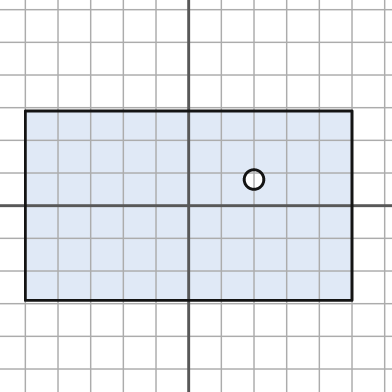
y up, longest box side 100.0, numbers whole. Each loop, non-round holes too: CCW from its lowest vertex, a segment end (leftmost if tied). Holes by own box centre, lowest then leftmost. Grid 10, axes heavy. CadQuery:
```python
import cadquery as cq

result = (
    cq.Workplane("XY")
    .moveTo(-50.0, -29.0)
    .lineTo(50.0, -29.0)
    .lineTo(50.0, 29.0)
    .lineTo(-50.0, 29.0)
    .close()
    .moveTo(20.0, 8.0)
    .circle(3.0)
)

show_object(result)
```